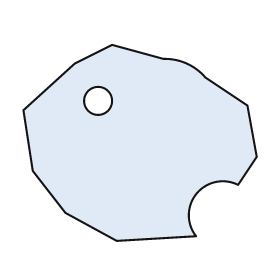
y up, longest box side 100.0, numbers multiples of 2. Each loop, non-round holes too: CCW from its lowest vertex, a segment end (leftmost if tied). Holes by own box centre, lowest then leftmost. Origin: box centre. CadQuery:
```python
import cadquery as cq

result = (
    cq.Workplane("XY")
    .moveTo(-10.0, -42.0)
    .lineTo(24.0, -40.0)
    .threePointArc((24.0, -22.0), (42.0, -18.0))
    .lineTo(50.0, -6.0)
    .lineTo(46.0, 16.0)
    .lineTo(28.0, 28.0)
    .threePointArc((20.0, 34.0), (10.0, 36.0))
    .lineTo(-12.0, 42.0)
    .lineTo(-28.0, 34.0)
    .lineTo(-50.0, 14.0)
    .lineTo(-46.0, -12.0)
    .lineTo(-32.0, -30.0)
    .close()
    .moveTo(-18.0, 18.0)
    .circle(6.0)
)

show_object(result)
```